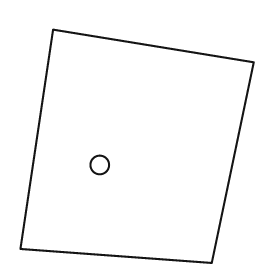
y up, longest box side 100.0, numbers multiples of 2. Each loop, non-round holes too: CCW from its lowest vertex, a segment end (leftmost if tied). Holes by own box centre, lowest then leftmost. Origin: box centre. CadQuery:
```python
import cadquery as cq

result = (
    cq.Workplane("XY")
    .moveTo(32.0, -50.0)
    .lineTo(50.0, 36.0)
    .lineTo(-36.0, 50.0)
    .lineTo(-50.0, -44.0)
    .close()
    .moveTo(-16.0, -8.0)
    .circle(4.0)
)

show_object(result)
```